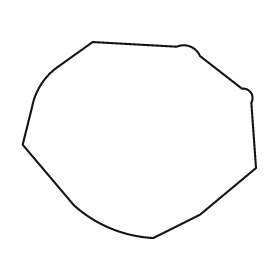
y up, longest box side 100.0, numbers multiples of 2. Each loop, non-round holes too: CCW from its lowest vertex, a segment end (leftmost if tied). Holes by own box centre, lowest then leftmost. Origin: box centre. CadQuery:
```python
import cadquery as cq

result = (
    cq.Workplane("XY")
    .moveTo(6.0, -42.0)
    .lineTo(26.0, -32.0)
    .lineTo(50.0, -12.0)
    .lineTo(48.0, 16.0)
    .threePointArc((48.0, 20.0), (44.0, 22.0))
    .lineTo(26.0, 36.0)
    .threePointArc((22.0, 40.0), (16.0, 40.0))
    .lineTo(-20.0, 42.0)
    .lineTo(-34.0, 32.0)
    .threePointArc((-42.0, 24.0), (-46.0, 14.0))
    .lineTo(-50.0, -2.0)
    .lineTo(-28.0, -28.0)
    .threePointArc((-12.0, -38.0), (6.0, -42.0))
    .close()
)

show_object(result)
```